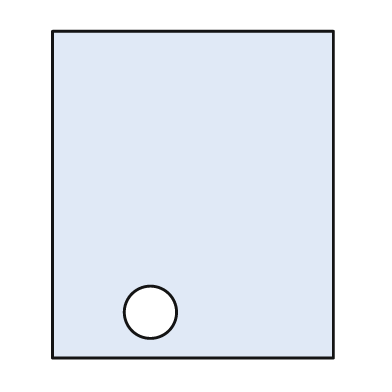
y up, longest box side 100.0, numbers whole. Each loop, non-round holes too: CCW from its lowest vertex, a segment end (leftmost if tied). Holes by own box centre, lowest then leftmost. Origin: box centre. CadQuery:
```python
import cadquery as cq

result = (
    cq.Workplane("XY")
    .moveTo(-43.0, -50.0)
    .lineTo(43.0, -50.0)
    .lineTo(43.0, 50.0)
    .lineTo(-43.0, 50.0)
    .close()
    .moveTo(-13.0, -36.0)
    .circle(8.0)
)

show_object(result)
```